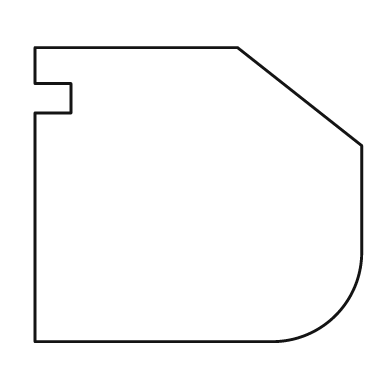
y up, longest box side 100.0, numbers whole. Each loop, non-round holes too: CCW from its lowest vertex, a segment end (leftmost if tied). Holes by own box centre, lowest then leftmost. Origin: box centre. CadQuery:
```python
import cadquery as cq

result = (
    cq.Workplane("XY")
    .moveTo(-50.0, -45.0)
    .lineTo(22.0, -45.0)
    .threePointArc((42.0, -37.0), (50.0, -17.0))
    .lineTo(50.0, 15.0)
    .lineTo(12.0, 45.0)
    .lineTo(-50.0, 45.0)
    .lineTo(-50.0, 34.0)
    .lineTo(-39.0, 34.0)
    .lineTo(-39.0, 25.0)
    .lineTo(-50.0, 25.0)
    .close()
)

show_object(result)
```